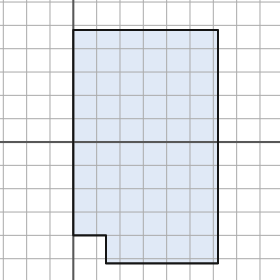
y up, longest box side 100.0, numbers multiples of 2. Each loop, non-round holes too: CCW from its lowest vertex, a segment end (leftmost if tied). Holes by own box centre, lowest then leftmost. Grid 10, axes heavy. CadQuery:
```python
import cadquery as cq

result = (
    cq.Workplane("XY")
    .moveTo(14.0, -52.0)
    .lineTo(62.0, -52.0)
    .lineTo(62.0, 48.0)
    .lineTo(0.0, 48.0)
    .lineTo(0.0, -40.0)
    .lineTo(14.0, -40.0)
    .close()
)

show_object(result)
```